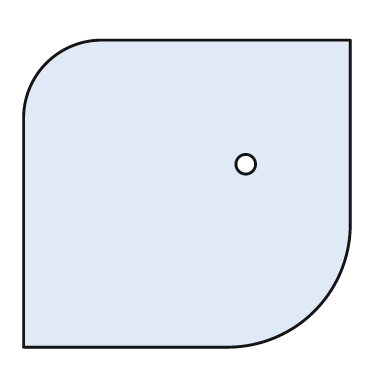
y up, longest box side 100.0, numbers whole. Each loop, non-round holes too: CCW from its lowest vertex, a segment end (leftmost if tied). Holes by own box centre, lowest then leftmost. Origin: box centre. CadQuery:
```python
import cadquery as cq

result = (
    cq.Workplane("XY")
    .moveTo(-50.0, -47.0)
    .lineTo(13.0, -47.0)
    .threePointArc((39.0, -36.0), (50.0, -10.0))
    .lineTo(50.0, 47.0)
    .lineTo(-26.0, 47.0)
    .threePointArc((-43.0, 40.0), (-50.0, 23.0))
    .close()
    .moveTo(18.0, 9.0)
    .circle(3.0)
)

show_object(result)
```